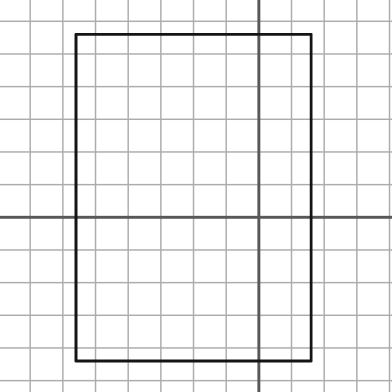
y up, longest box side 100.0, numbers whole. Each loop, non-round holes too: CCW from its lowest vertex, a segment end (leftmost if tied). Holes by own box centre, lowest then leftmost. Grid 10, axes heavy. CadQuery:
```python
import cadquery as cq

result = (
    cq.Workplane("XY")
    .moveTo(-56.0, -44.0)
    .lineTo(16.0, -44.0)
    .lineTo(16.0, 56.0)
    .lineTo(-56.0, 56.0)
    .close()
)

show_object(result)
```